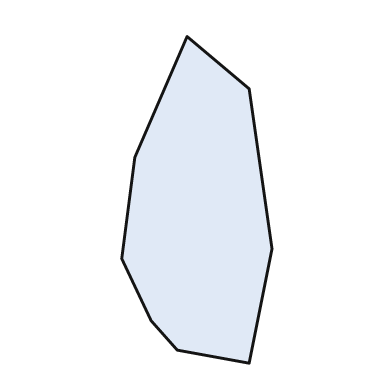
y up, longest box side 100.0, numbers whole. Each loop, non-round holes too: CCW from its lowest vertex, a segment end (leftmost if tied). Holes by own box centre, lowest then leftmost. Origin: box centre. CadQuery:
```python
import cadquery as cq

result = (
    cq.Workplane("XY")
    .moveTo(16.0, -50.0)
    .lineTo(23.0, -15.0)
    .lineTo(16.0, 34.0)
    .lineTo(-3.0, 50.0)
    .lineTo(-19.0, 13.0)
    .lineTo(-23.0, -18.0)
    .lineTo(-14.0, -37.0)
    .lineTo(-6.0, -46.0)
    .close()
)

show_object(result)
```